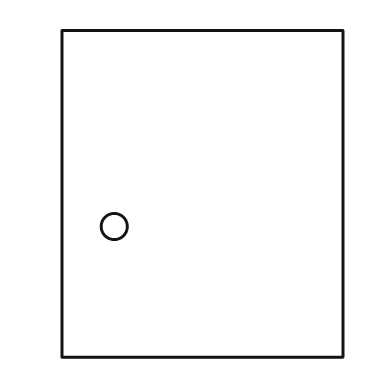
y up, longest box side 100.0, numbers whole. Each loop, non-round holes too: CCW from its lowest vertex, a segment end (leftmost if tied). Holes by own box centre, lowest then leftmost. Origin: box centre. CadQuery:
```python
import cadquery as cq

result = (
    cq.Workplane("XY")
    .moveTo(-43.0, -50.0)
    .lineTo(43.0, -50.0)
    .lineTo(43.0, 50.0)
    .lineTo(-43.0, 50.0)
    .close()
    .moveTo(-27.0, -10.0)
    .circle(4.0)
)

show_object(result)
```